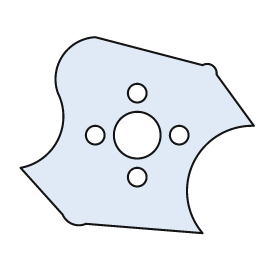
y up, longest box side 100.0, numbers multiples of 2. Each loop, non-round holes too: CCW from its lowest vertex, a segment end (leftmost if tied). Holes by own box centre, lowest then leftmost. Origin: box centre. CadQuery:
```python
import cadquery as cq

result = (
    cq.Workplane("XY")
    .moveTo(28.0, -42.0)
    .threePointArc((24.0, -12.0), (50.0, 4.0))
    .lineTo(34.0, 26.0)
    .threePointArc((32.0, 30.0), (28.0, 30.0))
    .lineTo(-18.0, 42.0)
    .threePointArc((-32.0, 34.0), (-34.0, 18.0))
    .threePointArc((-34.0, -2.0), (-50.0, -14.0))
    .lineTo(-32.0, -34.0)
    .threePointArc((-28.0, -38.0), (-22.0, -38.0))
    .close()
    .moveTo(0.0, -18.0)
    .circle(4.0)
    .moveTo(-18.0, 0.0)
    .circle(4.0)
    .moveTo(0.0, 0.0)
    .circle(10.0)
    .moveTo(18.0, 0.0)
    .circle(4.0)
    .moveTo(0.0, 18.0)
    .circle(4.0)
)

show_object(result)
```